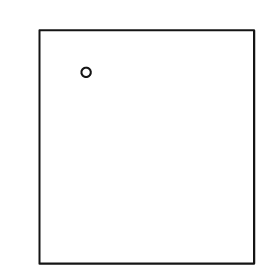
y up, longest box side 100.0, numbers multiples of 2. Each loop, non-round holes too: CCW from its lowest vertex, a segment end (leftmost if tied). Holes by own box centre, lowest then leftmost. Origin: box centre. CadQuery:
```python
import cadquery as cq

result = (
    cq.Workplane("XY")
    .moveTo(-46.0, -50.0)
    .lineTo(46.0, -50.0)
    .lineTo(46.0, 50.0)
    .lineTo(-46.0, 50.0)
    .close()
    .moveTo(-26.0, 32.0)
    .circle(2.0)
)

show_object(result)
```